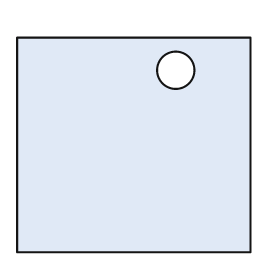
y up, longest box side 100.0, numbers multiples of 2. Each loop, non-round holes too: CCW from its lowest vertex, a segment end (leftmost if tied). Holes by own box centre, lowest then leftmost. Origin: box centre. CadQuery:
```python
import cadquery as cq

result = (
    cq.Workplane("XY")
    .moveTo(-50.0, -46.0)
    .lineTo(50.0, -46.0)
    .lineTo(50.0, 46.0)
    .lineTo(-50.0, 46.0)
    .close()
    .moveTo(18.0, 32.0)
    .circle(8.0)
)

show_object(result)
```